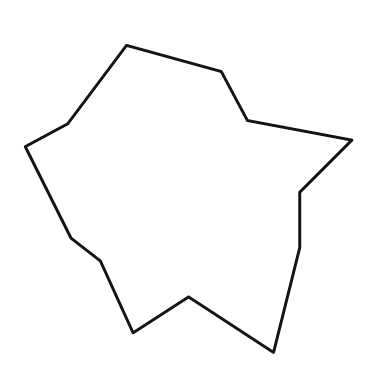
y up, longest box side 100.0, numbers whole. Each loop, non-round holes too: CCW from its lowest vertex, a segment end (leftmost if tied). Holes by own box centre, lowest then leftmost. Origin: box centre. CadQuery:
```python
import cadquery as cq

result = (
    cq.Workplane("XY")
    .moveTo(26.0, -47.0)
    .lineTo(34.0, -15.0)
    .lineTo(34.0, 2.0)
    .lineTo(50.0, 18.0)
    .lineTo(18.0, 24.0)
    .lineTo(10.0, 39.0)
    .lineTo(-19.0, 47.0)
    .lineTo(-37.0, 23.0)
    .lineTo(-50.0, 16.0)
    .lineTo(-36.0, -12.0)
    .lineTo(-27.0, -19.0)
    .lineTo(-17.0, -41.0)
    .lineTo(0.0, -30.0)
    .close()
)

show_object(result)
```